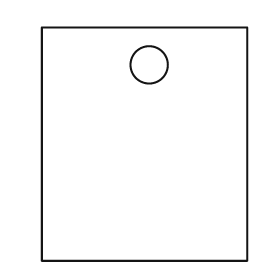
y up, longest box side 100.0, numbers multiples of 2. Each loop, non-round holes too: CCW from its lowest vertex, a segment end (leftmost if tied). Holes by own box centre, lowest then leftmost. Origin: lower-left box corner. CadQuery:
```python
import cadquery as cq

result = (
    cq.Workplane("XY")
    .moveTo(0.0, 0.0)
    .lineTo(88.0, 0.0)
    .lineTo(88.0, 100.0)
    .lineTo(0.0, 100.0)
    .close()
    .moveTo(46.0, 84.0)
    .circle(8.0)
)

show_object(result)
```